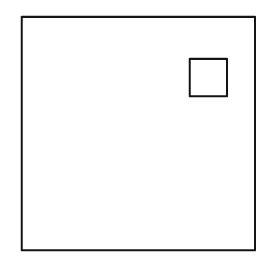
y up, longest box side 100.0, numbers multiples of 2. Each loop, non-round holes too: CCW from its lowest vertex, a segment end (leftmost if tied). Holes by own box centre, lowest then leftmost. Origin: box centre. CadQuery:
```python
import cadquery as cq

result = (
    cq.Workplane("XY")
    .moveTo(-50.0, -50.0)
    .lineTo(50.0, -50.0)
    .lineTo(50.0, 50.0)
    .lineTo(-50.0, 50.0)
    .close()
    .moveTo(22.0, 16.0)
    .lineTo(38.0, 16.0)
    .lineTo(38.0, 32.0)
    .lineTo(22.0, 32.0)
    .close()
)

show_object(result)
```